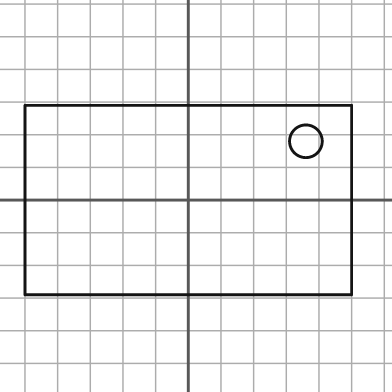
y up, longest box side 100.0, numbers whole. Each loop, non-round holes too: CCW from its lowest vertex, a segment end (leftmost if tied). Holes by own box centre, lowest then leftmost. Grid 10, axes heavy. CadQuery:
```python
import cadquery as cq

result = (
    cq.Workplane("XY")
    .moveTo(-50.0, -29.0)
    .lineTo(50.0, -29.0)
    .lineTo(50.0, 29.0)
    .lineTo(-50.0, 29.0)
    .close()
    .moveTo(36.0, 18.0)
    .circle(5.0)
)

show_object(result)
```